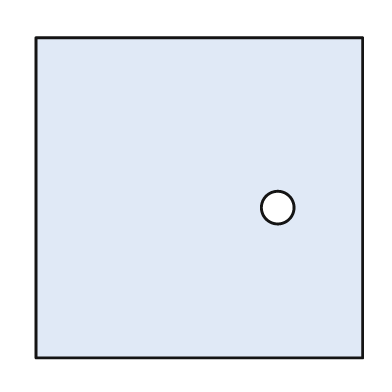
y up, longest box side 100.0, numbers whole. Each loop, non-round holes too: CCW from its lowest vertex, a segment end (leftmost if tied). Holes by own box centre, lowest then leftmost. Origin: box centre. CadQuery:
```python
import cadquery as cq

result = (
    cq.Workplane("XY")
    .moveTo(-50.0, -49.0)
    .lineTo(50.0, -49.0)
    .lineTo(50.0, 49.0)
    .lineTo(-50.0, 49.0)
    .close()
    .moveTo(24.0, -3.0)
    .circle(5.0)
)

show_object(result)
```